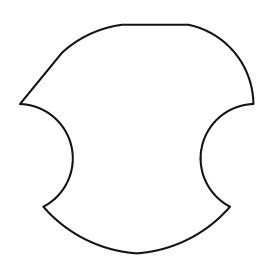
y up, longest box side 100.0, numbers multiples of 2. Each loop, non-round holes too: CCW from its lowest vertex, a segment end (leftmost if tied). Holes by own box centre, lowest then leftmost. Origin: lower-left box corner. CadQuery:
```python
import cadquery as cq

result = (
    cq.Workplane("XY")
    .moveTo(50.0, 0.0)
    .threePointArc((72.0, 6.0), (90.0, 20.0))
    .threePointArc((78.0, 46.0), (100.0, 64.0))
    .threePointArc((92.0, 86.0), (72.0, 98.0))
    .lineTo(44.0, 98.0)
    .threePointArc((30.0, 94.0), (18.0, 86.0))
    .lineTo(0.0, 64.0)
    .threePointArc((22.0, 46.0), (10.0, 20.0))
    .threePointArc((28.0, 6.0), (50.0, 0.0))
    .close()
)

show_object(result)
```